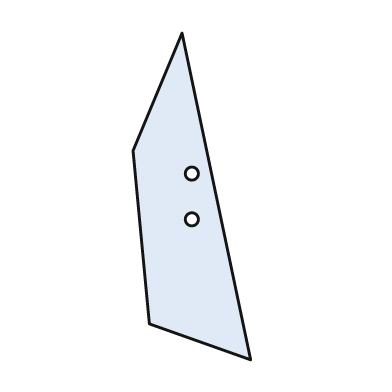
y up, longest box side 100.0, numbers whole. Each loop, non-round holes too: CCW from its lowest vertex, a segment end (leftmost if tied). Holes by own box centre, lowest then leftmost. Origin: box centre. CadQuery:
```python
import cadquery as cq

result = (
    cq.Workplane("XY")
    .moveTo(18.0, -50.0)
    .lineTo(-3.0, 50.0)
    .lineTo(-18.0, 14.0)
    .lineTo(-13.0, -39.0)
    .close()
    .moveTo(0.0, -7.0)
    .circle(2.0)
    .moveTo(0.0, 7.0)
    .circle(2.0)
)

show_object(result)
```